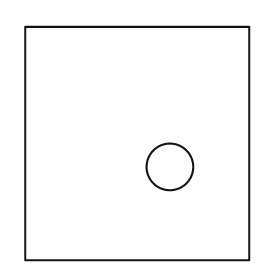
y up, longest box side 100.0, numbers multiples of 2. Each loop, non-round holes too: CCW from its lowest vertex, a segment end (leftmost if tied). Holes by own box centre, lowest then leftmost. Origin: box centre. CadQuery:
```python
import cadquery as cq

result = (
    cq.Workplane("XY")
    .moveTo(-48.0, -50.0)
    .lineTo(48.0, -50.0)
    .lineTo(48.0, 50.0)
    .lineTo(-48.0, 50.0)
    .close()
    .moveTo(14.0, -10.0)
    .circle(10.0)
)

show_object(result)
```